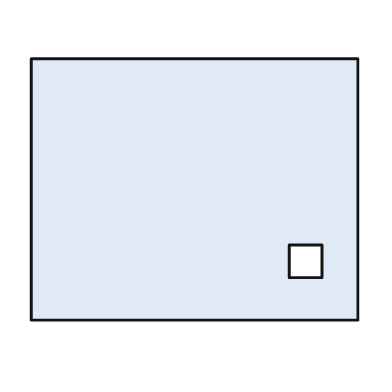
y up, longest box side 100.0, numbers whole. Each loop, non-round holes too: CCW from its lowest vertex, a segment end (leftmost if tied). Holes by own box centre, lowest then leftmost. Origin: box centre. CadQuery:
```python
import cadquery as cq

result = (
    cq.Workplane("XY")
    .moveTo(-50.0, -40.0)
    .lineTo(50.0, -40.0)
    .lineTo(50.0, 40.0)
    .lineTo(-50.0, 40.0)
    .close()
    .moveTo(29.0, -27.0)
    .lineTo(39.0, -27.0)
    .lineTo(39.0, -17.0)
    .lineTo(29.0, -17.0)
    .close()
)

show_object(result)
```